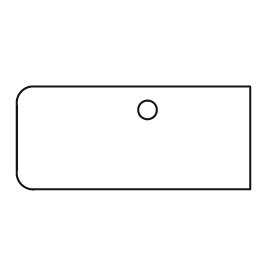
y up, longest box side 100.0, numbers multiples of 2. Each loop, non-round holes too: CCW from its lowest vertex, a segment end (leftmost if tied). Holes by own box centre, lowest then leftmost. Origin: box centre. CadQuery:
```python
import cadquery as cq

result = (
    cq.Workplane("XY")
    .moveTo(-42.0, -22.0)
    .lineTo(50.0, -22.0)
    .lineTo(50.0, 22.0)
    .lineTo(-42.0, 22.0)
    .threePointArc((-48.0, 20.0), (-50.0, 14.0))
    .lineTo(-50.0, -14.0)
    .threePointArc((-48.0, -20.0), (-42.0, -22.0))
    .close()
    .moveTo(6.0, 12.0)
    .circle(4.0)
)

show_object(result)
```